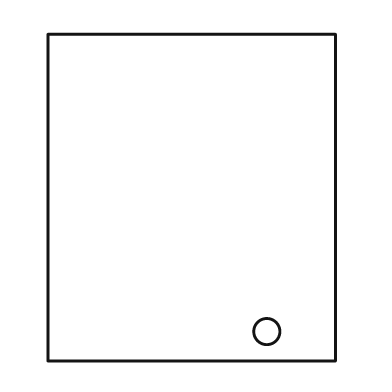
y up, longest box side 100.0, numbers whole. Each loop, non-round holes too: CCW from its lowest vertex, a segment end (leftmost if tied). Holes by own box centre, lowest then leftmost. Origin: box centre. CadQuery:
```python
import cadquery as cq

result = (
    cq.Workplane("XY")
    .moveTo(-44.0, -50.0)
    .lineTo(44.0, -50.0)
    .lineTo(44.0, 50.0)
    .lineTo(-44.0, 50.0)
    .close()
    .moveTo(23.0, -41.0)
    .circle(4.0)
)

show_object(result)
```